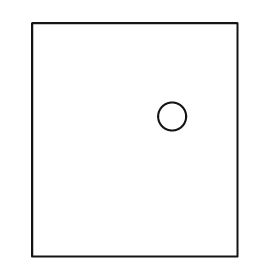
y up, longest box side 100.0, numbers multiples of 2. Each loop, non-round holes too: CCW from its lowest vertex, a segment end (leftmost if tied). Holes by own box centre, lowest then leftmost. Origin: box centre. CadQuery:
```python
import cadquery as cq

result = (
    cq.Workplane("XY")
    .moveTo(-44.0, -50.0)
    .lineTo(44.0, -50.0)
    .lineTo(44.0, 50.0)
    .lineTo(-44.0, 50.0)
    .close()
    .moveTo(16.0, 10.0)
    .circle(6.0)
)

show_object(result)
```